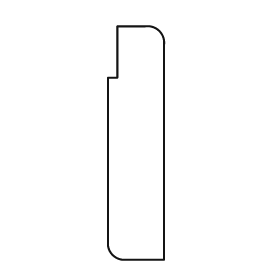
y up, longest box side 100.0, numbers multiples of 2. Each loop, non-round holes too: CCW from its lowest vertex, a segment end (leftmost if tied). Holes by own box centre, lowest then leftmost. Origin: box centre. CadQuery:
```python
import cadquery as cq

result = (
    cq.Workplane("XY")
    .moveTo(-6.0, -50.0)
    .lineTo(12.0, -50.0)
    .lineTo(12.0, 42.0)
    .threePointArc((10.0, 48.0), (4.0, 50.0))
    .lineTo(-8.0, 50.0)
    .lineTo(-8.0, 28.0)
    .lineTo(-12.0, 28.0)
    .lineTo(-12.0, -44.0)
    .threePointArc((-10.0, -48.0), (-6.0, -50.0))
    .close()
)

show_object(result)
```